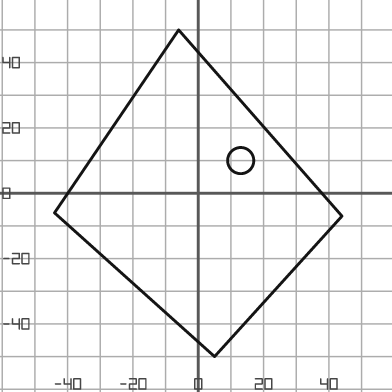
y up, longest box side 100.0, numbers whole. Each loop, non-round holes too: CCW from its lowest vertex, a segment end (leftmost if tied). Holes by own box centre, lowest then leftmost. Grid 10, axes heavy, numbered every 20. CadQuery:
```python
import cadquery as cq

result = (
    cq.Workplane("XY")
    .moveTo(5.0, -50.0)
    .lineTo(44.0, -7.0)
    .lineTo(-6.0, 50.0)
    .lineTo(-44.0, -6.0)
    .close()
    .moveTo(13.0, 10.0)
    .circle(4.0)
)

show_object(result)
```